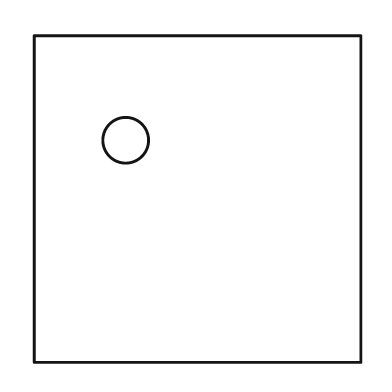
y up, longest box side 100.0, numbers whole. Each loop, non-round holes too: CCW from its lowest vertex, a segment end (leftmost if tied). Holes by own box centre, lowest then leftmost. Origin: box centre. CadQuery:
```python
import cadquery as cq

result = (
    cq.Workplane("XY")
    .moveTo(-50.0, -50.0)
    .lineTo(50.0, -50.0)
    .lineTo(50.0, 50.0)
    .lineTo(-50.0, 50.0)
    .close()
    .moveTo(-22.0, 18.0)
    .circle(7.0)
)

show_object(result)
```